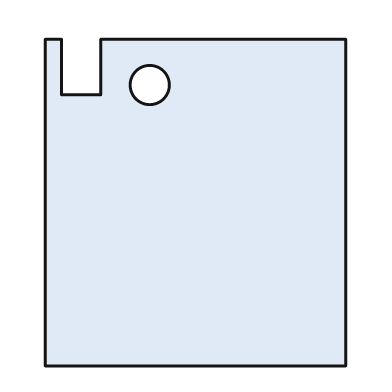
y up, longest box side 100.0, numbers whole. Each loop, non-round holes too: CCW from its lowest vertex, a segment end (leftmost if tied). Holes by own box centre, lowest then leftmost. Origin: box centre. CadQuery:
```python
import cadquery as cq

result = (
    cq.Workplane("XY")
    .moveTo(-46.0, -50.0)
    .lineTo(46.0, -50.0)
    .lineTo(46.0, 50.0)
    .lineTo(-29.0, 50.0)
    .lineTo(-29.0, 33.0)
    .lineTo(-41.0, 33.0)
    .lineTo(-41.0, 50.0)
    .lineTo(-46.0, 50.0)
    .close()
    .moveTo(-14.0, 36.0)
    .circle(6.0)
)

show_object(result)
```